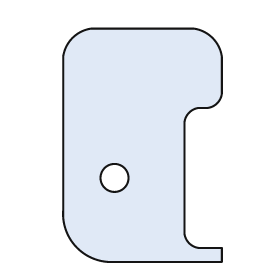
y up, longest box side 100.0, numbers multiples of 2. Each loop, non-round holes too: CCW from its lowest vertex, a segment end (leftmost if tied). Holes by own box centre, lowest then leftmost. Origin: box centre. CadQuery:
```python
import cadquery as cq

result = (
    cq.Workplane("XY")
    .moveTo(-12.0, -50.0)
    .lineTo(34.0, -50.0)
    .lineTo(34.0, -44.0)
    .lineTo(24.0, -44.0)
    .threePointArc((20.0, -42.0), (18.0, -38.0))
    .lineTo(18.0, 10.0)
    .threePointArc((20.0, 14.0), (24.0, 16.0))
    .lineTo(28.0, 16.0)
    .threePointArc((32.0, 18.0), (34.0, 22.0))
    .lineTo(34.0, 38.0)
    .threePointArc((30.0, 46.0), (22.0, 50.0))
    .lineTo(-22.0, 50.0)
    .threePointArc((-30.0, 46.0), (-34.0, 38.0))
    .lineTo(-34.0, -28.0)
    .threePointArc((-28.0, -44.0), (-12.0, -50.0))
    .close()
    .moveTo(-12.0, -14.0)
    .circle(6.0)
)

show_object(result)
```